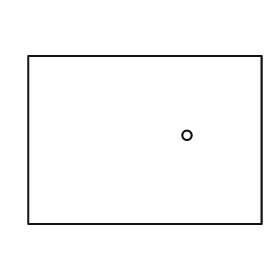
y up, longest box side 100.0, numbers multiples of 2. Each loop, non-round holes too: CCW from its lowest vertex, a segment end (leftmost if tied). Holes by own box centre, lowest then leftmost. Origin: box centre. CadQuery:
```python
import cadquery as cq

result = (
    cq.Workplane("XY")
    .moveTo(-50.0, -36.0)
    .lineTo(50.0, -36.0)
    .lineTo(50.0, 36.0)
    .lineTo(-50.0, 36.0)
    .close()
    .moveTo(18.0, 2.0)
    .circle(2.0)
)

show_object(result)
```